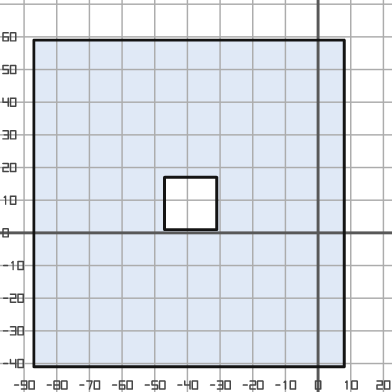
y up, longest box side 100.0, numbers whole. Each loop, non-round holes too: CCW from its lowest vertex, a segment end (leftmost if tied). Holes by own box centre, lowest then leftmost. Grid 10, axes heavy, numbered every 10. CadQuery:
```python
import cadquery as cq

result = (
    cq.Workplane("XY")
    .moveTo(-87.0, -41.0)
    .lineTo(8.0, -41.0)
    .lineTo(8.0, 59.0)
    .lineTo(-87.0, 59.0)
    .close()
    .moveTo(-47.0, 1.0)
    .lineTo(-31.0, 1.0)
    .lineTo(-31.0, 17.0)
    .lineTo(-47.0, 17.0)
    .close()
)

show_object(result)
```